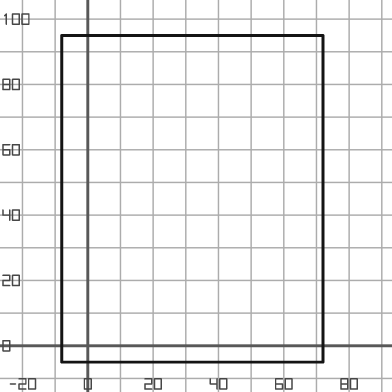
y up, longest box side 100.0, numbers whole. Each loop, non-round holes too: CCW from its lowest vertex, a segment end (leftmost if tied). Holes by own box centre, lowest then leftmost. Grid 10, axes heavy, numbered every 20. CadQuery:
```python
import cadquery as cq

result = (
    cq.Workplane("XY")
    .moveTo(-8.0, -5.0)
    .lineTo(72.0, -5.0)
    .lineTo(72.0, 95.0)
    .lineTo(-8.0, 95.0)
    .close()
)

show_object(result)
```